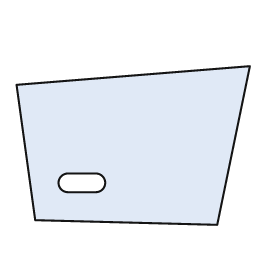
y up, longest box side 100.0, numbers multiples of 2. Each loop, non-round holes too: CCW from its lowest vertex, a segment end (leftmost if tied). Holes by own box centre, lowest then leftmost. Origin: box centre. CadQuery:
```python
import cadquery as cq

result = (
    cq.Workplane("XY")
    .moveTo(36.0, -34.0)
    .lineTo(50.0, 34.0)
    .lineTo(-50.0, 26.0)
    .lineTo(-42.0, -32.0)
    .close()
    .moveTo(-28.0, -20.0)
    .lineTo(-16.0, -20.0)
    .threePointArc((-12.0, -16.0), (-16.0, -12.0))
    .lineTo(-28.0, -12.0)
    .threePointArc((-32.0, -16.0), (-28.0, -20.0))
    .close()
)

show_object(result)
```